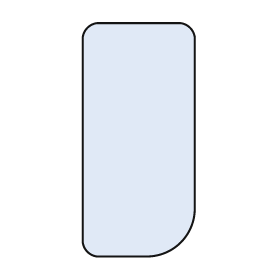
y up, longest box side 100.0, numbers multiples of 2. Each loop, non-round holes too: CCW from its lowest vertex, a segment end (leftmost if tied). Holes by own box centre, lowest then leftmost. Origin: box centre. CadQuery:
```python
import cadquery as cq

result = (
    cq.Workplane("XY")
    .moveTo(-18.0, -50.0)
    .lineTo(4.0, -50.0)
    .threePointArc((18.0, -44.0), (24.0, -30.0))
    .lineTo(24.0, 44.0)
    .threePointArc((22.0, 48.0), (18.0, 50.0))
    .lineTo(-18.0, 50.0)
    .threePointArc((-22.0, 48.0), (-24.0, 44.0))
    .lineTo(-24.0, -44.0)
    .threePointArc((-22.0, -48.0), (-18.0, -50.0))
    .close()
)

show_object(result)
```